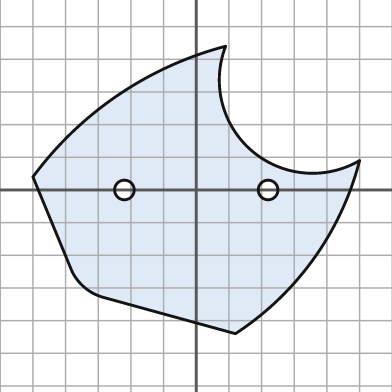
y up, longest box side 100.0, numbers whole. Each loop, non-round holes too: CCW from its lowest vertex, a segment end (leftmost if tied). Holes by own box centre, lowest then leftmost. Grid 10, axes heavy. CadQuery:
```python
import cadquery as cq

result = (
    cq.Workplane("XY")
    .moveTo(12.0, -44.0)
    .threePointArc((36.0, -21.0), (50.0, 9.0))
    .threePointArc((17.0, 12.0), (9.0, 44.0))
    .threePointArc((-24.0, 29.0), (-50.0, 4.0))
    .lineTo(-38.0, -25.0)
    .threePointArc((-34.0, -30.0), (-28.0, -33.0))
    .close()
    .moveTo(-22.0, 0.0)
    .circle(3.0)
    .moveTo(22.0, 0.0)
    .circle(3.0)
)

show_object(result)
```